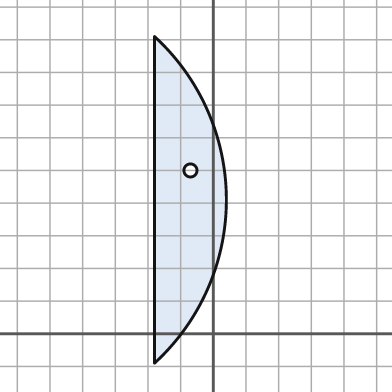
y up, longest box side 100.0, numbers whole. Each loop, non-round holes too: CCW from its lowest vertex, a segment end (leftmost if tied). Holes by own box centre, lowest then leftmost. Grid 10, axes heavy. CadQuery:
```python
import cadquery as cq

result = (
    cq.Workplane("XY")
    .moveTo(-18.0, -9.0)
    .threePointArc((4.0, 41.0), (-18.0, 91.0))
    .close()
    .moveTo(-7.0, 50.0)
    .circle(2.0)
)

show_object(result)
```